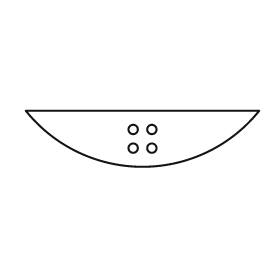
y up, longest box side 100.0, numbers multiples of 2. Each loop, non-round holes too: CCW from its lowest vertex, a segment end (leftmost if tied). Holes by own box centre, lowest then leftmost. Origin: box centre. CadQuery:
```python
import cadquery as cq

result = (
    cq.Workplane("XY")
    .moveTo(-50.0, 12.0)
    .threePointArc((0.0, -12.0), (50.0, 12.0))
    .close()
    .moveTo(-4.0, -4.0)
    .circle(2.0)
    .moveTo(4.0, -4.0)
    .circle(2.0)
    .moveTo(-4.0, 4.0)
    .circle(2.0)
    .moveTo(4.0, 4.0)
    .circle(2.0)
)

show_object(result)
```